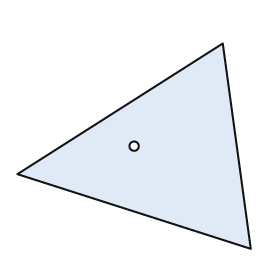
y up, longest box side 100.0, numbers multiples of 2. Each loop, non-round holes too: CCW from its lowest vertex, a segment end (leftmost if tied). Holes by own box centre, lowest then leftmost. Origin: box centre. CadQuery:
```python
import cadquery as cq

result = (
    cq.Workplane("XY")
    .moveTo(50.0, -44.0)
    .lineTo(38.0, 44.0)
    .lineTo(-50.0, -12.0)
    .close()
    .moveTo(0.0, 0.0)
    .circle(2.0)
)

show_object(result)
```